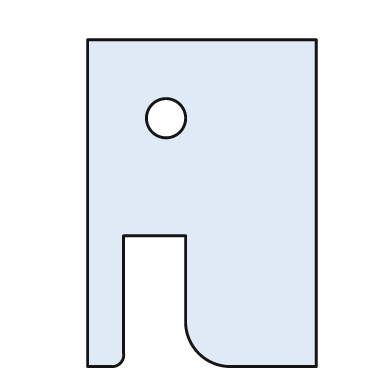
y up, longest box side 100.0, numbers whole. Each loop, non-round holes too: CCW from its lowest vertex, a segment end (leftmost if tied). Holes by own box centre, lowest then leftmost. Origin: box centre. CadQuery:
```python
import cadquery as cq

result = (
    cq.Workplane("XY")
    .moveTo(-35.0, -50.0)
    .lineTo(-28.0, -50.0)
    .threePointArc((-25.0, -49.0), (-24.0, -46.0))
    .lineTo(-24.0, -10.0)
    .lineTo(-5.0, -10.0)
    .lineTo(-5.0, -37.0)
    .threePointArc((-1.0, -46.0), (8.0, -50.0))
    .lineTo(35.0, -50.0)
    .lineTo(35.0, 50.0)
    .lineTo(-35.0, 50.0)
    .close()
    .moveTo(-11.0, 26.0)
    .circle(6.0)
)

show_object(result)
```